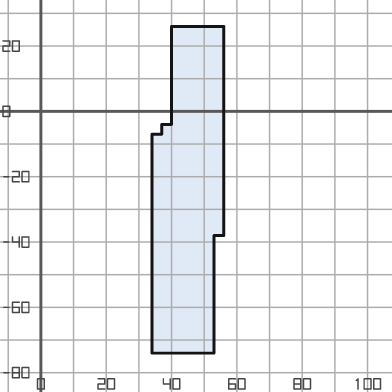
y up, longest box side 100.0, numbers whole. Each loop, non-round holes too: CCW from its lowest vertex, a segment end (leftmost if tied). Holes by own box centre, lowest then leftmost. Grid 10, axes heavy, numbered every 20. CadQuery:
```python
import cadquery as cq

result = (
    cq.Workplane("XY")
    .moveTo(34.0, -74.0)
    .lineTo(53.0, -74.0)
    .lineTo(53.0, -38.0)
    .lineTo(56.0, -38.0)
    .lineTo(56.0, 26.0)
    .lineTo(40.0, 26.0)
    .lineTo(40.0, -4.0)
    .lineTo(37.0, -4.0)
    .lineTo(37.0, -7.0)
    .lineTo(34.0, -7.0)
    .close()
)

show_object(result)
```